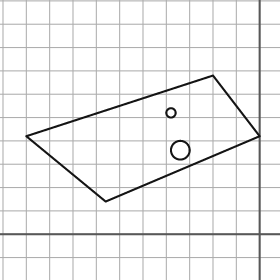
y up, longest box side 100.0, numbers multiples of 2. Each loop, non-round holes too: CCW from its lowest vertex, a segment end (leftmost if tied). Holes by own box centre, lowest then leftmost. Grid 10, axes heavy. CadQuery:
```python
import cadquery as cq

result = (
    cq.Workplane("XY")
    .moveTo(-66.0, 14.0)
    .lineTo(0.0, 42.0)
    .lineTo(-20.0, 68.0)
    .lineTo(-100.0, 42.0)
    .close()
    .moveTo(-34.0, 36.0)
    .circle(4.0)
    .moveTo(-38.0, 52.0)
    .circle(2.0)
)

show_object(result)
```